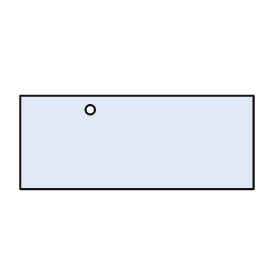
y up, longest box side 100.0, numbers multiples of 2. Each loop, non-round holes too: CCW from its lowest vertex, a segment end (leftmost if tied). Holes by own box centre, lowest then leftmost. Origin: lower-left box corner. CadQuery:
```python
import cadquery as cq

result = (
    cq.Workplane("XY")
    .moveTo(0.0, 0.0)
    .lineTo(100.0, 0.0)
    .lineTo(100.0, 40.0)
    .lineTo(0.0, 40.0)
    .close()
    .moveTo(30.0, 34.0)
    .circle(2.0)
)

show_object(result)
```